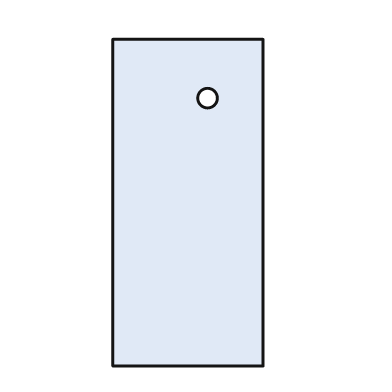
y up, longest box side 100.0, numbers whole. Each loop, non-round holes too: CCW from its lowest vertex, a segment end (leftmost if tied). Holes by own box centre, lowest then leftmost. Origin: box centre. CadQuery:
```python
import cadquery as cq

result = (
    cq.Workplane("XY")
    .moveTo(-23.0, -50.0)
    .lineTo(23.0, -50.0)
    .lineTo(23.0, 50.0)
    .lineTo(-23.0, 50.0)
    .close()
    .moveTo(6.0, 32.0)
    .circle(3.0)
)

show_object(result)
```